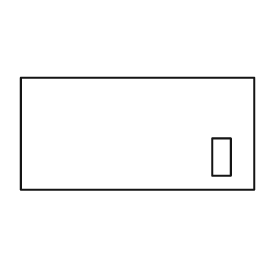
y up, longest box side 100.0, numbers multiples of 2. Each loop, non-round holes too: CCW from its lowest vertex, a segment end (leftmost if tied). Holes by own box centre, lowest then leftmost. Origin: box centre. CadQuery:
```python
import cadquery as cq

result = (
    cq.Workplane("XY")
    .moveTo(-50.0, -24.0)
    .lineTo(50.0, -24.0)
    .lineTo(50.0, 24.0)
    .lineTo(-50.0, 24.0)
    .close()
    .moveTo(32.0, -18.0)
    .lineTo(40.0, -18.0)
    .lineTo(40.0, -2.0)
    .lineTo(32.0, -2.0)
    .close()
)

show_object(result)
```